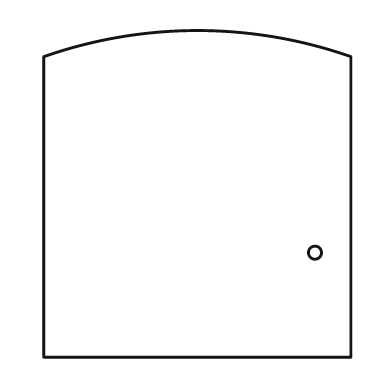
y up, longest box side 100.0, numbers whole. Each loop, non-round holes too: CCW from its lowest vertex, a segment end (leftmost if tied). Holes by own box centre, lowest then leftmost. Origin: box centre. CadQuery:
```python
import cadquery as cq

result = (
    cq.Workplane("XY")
    .moveTo(-47.0, -50.0)
    .lineTo(47.0, -50.0)
    .lineTo(47.0, 42.0)
    .threePointArc((0.0, 50.0), (-47.0, 42.0))
    .close()
    .moveTo(36.0, -18.0)
    .circle(2.0)
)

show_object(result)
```